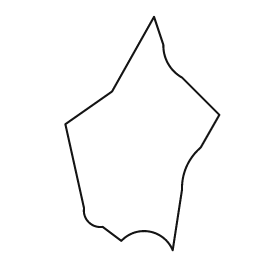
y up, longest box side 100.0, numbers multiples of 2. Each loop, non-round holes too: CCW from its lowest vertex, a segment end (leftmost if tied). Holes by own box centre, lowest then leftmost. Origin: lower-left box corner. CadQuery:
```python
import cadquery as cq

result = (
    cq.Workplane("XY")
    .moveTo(46.0, 0.0)
    .lineTo(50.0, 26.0)
    .threePointArc((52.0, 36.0), (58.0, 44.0))
    .lineTo(66.0, 58.0)
    .lineTo(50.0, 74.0)
    .threePointArc((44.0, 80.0), (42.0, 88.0))
    .lineTo(38.0, 100.0)
    .lineTo(20.0, 68.0)
    .lineTo(0.0, 54.0)
    .lineTo(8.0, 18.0)
    .threePointArc((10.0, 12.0), (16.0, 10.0))
    .lineTo(24.0, 4.0)
    .threePointArc((36.0, 8.0), (46.0, 0.0))
    .close()
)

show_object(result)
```